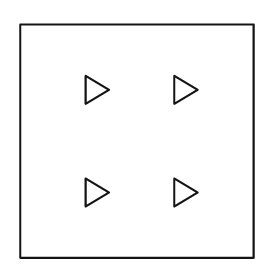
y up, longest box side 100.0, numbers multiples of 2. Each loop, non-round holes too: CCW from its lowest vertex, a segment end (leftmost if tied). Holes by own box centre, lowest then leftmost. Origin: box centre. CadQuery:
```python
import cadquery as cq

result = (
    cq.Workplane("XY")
    .moveTo(-50.0, -50.0)
    .lineTo(50.0, -50.0)
    .lineTo(50.0, 50.0)
    .lineTo(-50.0, 50.0)
    .close()
    .moveTo(-22.0, -28.0)
    .lineTo(-12.0, -22.0)
    .lineTo(-22.0, -16.0)
    .close()
    .moveTo(16.0, -28.0)
    .lineTo(26.0, -22.0)
    .lineTo(16.0, -16.0)
    .close()
    .moveTo(-22.0, 16.0)
    .lineTo(-12.0, 22.0)
    .lineTo(-22.0, 28.0)
    .close()
    .moveTo(16.0, 16.0)
    .lineTo(26.0, 22.0)
    .lineTo(16.0, 28.0)
    .close()
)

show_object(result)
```